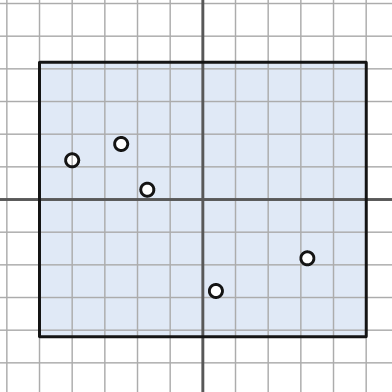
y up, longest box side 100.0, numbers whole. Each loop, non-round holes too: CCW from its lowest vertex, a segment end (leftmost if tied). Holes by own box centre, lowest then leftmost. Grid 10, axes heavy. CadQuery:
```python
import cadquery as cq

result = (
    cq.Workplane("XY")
    .moveTo(-50.0, -42.0)
    .lineTo(50.0, -42.0)
    .lineTo(50.0, 42.0)
    .lineTo(-50.0, 42.0)
    .close()
    .moveTo(4.0, -28.0)
    .circle(2.0)
    .moveTo(32.0, -18.0)
    .circle(2.0)
    .moveTo(-17.0, 3.0)
    .circle(2.0)
    .moveTo(-40.0, 12.0)
    .circle(2.0)
    .moveTo(-25.0, 17.0)
    .circle(2.0)
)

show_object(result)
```